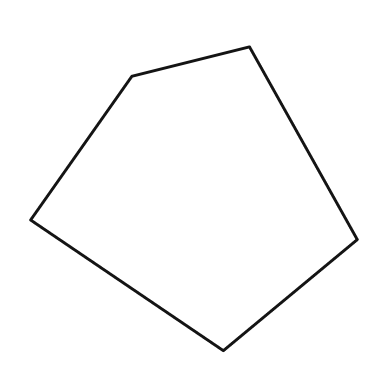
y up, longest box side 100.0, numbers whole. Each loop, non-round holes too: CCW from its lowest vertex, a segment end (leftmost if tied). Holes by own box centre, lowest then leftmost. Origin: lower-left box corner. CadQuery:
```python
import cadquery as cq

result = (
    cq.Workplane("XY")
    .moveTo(59.0, 0.0)
    .lineTo(100.0, 34.0)
    .lineTo(67.0, 93.0)
    .lineTo(31.0, 84.0)
    .lineTo(0.0, 40.0)
    .close()
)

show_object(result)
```